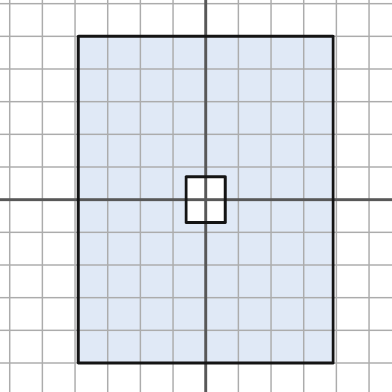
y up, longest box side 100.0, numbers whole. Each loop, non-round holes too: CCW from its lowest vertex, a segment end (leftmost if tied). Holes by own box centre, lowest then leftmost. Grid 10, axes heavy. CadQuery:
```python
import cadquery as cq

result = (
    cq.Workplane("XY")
    .moveTo(-39.0, -50.0)
    .lineTo(39.0, -50.0)
    .lineTo(39.0, 50.0)
    .lineTo(-39.0, 50.0)
    .close()
    .moveTo(-6.0, -7.0)
    .lineTo(6.0, -7.0)
    .lineTo(6.0, 7.0)
    .lineTo(-6.0, 7.0)
    .close()
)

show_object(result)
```